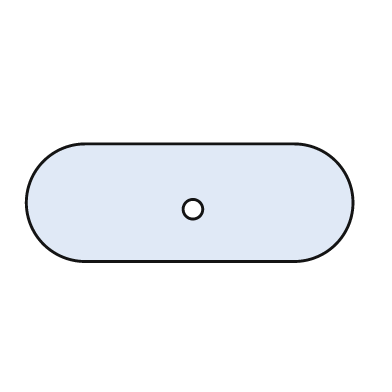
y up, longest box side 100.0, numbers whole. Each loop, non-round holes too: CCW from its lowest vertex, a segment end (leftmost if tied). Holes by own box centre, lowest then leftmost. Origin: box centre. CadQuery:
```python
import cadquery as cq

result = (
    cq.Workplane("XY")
    .moveTo(-32.0, -18.0)
    .lineTo(32.0, -18.0)
    .threePointArc((50.0, 0.0), (32.0, 18.0))
    .lineTo(-32.0, 18.0)
    .threePointArc((-50.0, 0.0), (-32.0, -18.0))
    .close()
    .moveTo(1.0, -2.0)
    .circle(3.0)
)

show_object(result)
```